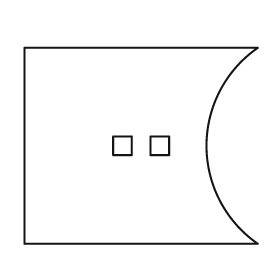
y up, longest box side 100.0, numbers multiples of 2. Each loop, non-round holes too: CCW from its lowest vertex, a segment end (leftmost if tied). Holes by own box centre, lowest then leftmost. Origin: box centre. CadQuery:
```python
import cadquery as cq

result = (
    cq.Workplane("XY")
    .moveTo(-50.0, -42.0)
    .lineTo(50.0, -42.0)
    .threePointArc((28.0, 0.0), (50.0, 42.0))
    .lineTo(-50.0, 42.0)
    .close()
    .moveTo(-12.0, -4.0)
    .lineTo(-4.0, -4.0)
    .lineTo(-4.0, 4.0)
    .lineTo(-12.0, 4.0)
    .close()
    .moveTo(4.0, -4.0)
    .lineTo(12.0, -4.0)
    .lineTo(12.0, 4.0)
    .lineTo(4.0, 4.0)
    .close()
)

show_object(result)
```